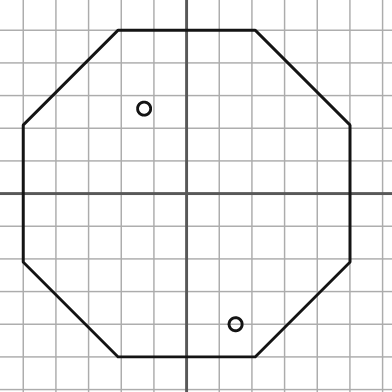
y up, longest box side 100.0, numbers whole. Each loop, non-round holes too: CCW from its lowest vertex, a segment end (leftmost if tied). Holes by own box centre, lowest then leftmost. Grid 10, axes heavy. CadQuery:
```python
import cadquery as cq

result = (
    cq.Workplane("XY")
    .moveTo(-21.0, -50.0)
    .lineTo(21.0, -50.0)
    .lineTo(50.0, -21.0)
    .lineTo(50.0, 21.0)
    .lineTo(21.0, 50.0)
    .lineTo(-21.0, 50.0)
    .lineTo(-50.0, 21.0)
    .lineTo(-50.0, -21.0)
    .close()
    .moveTo(15.0, -40.0)
    .circle(2.0)
    .moveTo(-13.0, 26.0)
    .circle(2.0)
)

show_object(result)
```